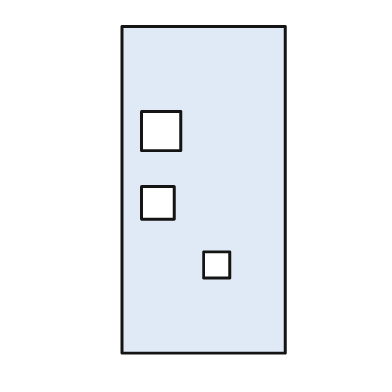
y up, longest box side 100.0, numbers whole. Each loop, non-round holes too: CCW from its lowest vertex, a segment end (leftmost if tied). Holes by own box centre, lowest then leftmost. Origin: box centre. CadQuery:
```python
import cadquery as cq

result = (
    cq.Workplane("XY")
    .moveTo(-25.0, -50.0)
    .lineTo(25.0, -50.0)
    .lineTo(25.0, 50.0)
    .lineTo(-25.0, 50.0)
    .close()
    .moveTo(0.0, -27.0)
    .lineTo(8.0, -27.0)
    .lineTo(8.0, -19.0)
    .lineTo(0.0, -19.0)
    .close()
    .moveTo(-19.0, -9.0)
    .lineTo(-9.0, -9.0)
    .lineTo(-9.0, 1.0)
    .lineTo(-19.0, 1.0)
    .close()
    .moveTo(-19.0, 12.0)
    .lineTo(-7.0, 12.0)
    .lineTo(-7.0, 24.0)
    .lineTo(-19.0, 24.0)
    .close()
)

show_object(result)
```